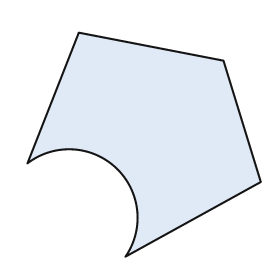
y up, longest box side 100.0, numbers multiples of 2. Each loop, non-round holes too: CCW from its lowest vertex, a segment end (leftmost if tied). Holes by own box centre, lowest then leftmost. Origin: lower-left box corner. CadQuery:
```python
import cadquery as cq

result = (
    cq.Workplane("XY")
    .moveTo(42.0, 0.0)
    .lineTo(100.0, 32.0)
    .lineTo(84.0, 84.0)
    .lineTo(22.0, 96.0)
    .lineTo(0.0, 40.0)
    .threePointArc((38.0, 38.0), (42.0, 0.0))
    .close()
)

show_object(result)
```